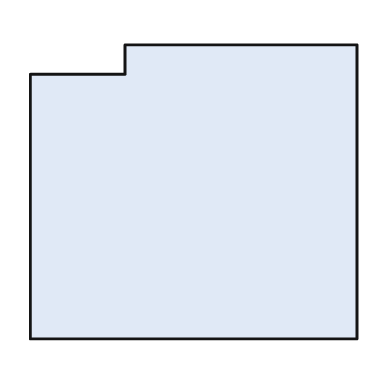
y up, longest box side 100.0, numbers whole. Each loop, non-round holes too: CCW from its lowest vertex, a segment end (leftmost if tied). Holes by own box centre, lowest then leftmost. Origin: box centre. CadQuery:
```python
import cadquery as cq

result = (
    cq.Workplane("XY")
    .moveTo(-50.0, -45.0)
    .lineTo(50.0, -45.0)
    .lineTo(50.0, 45.0)
    .lineTo(-21.0, 45.0)
    .lineTo(-21.0, 36.0)
    .lineTo(-50.0, 36.0)
    .close()
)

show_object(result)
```